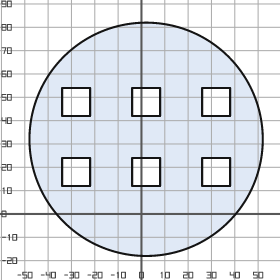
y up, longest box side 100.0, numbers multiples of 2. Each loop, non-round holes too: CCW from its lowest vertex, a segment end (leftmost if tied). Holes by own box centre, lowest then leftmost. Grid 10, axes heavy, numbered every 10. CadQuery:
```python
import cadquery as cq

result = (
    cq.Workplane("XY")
    .moveTo(2.0, 32.0)
    .circle(50.0)
    .moveTo(-34.0, 12.0)
    .lineTo(-22.0, 12.0)
    .lineTo(-22.0, 24.0)
    .lineTo(-34.0, 24.0)
    .close()
    .moveTo(-4.0, 12.0)
    .lineTo(8.0, 12.0)
    .lineTo(8.0, 24.0)
    .lineTo(-4.0, 24.0)
    .close()
    .moveTo(26.0, 12.0)
    .lineTo(38.0, 12.0)
    .lineTo(38.0, 24.0)
    .lineTo(26.0, 24.0)
    .close()
    .moveTo(-34.0, 42.0)
    .lineTo(-22.0, 42.0)
    .lineTo(-22.0, 54.0)
    .lineTo(-34.0, 54.0)
    .close()
    .moveTo(-4.0, 42.0)
    .lineTo(8.0, 42.0)
    .lineTo(8.0, 54.0)
    .lineTo(-4.0, 54.0)
    .close()
    .moveTo(26.0, 42.0)
    .lineTo(38.0, 42.0)
    .lineTo(38.0, 54.0)
    .lineTo(26.0, 54.0)
    .close()
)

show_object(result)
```